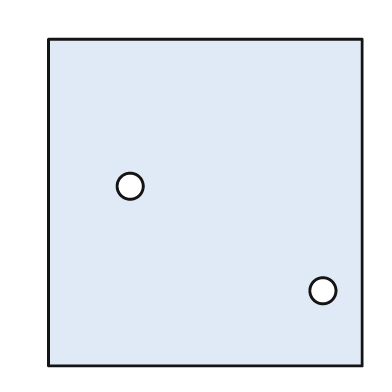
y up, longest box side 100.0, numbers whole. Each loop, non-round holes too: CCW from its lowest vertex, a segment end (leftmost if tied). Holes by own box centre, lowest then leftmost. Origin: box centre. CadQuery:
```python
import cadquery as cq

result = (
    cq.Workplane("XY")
    .moveTo(-48.0, -50.0)
    .lineTo(48.0, -50.0)
    .lineTo(48.0, 50.0)
    .lineTo(-48.0, 50.0)
    .close()
    .moveTo(36.0, -27.0)
    .circle(4.0)
    .moveTo(-23.0, 5.0)
    .circle(4.0)
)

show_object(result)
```